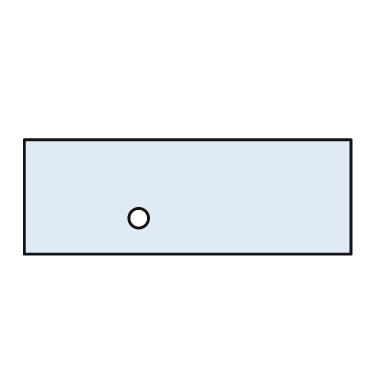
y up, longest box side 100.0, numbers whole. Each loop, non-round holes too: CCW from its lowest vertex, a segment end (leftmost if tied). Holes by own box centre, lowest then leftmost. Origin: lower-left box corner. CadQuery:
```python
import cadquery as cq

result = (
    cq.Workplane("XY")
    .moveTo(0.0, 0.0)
    .lineTo(100.0, 0.0)
    .lineTo(100.0, 35.0)
    .lineTo(0.0, 35.0)
    .close()
    .moveTo(35.0, 11.0)
    .circle(3.0)
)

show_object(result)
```